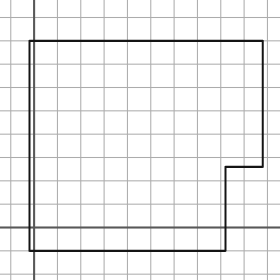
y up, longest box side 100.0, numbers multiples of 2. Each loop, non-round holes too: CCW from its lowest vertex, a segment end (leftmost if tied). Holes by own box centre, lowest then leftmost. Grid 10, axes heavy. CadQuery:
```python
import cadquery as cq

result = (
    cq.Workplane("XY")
    .moveTo(-2.0, -10.0)
    .lineTo(82.0, -10.0)
    .lineTo(82.0, 26.0)
    .lineTo(98.0, 26.0)
    .lineTo(98.0, 80.0)
    .lineTo(-2.0, 80.0)
    .close()
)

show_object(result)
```